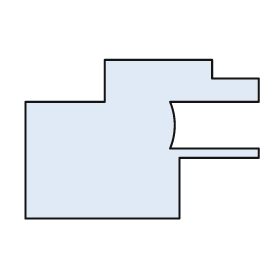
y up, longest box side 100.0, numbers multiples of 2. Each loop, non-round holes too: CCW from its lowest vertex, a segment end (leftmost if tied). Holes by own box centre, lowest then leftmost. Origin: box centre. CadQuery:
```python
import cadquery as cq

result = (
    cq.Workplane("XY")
    .moveTo(-50.0, -34.0)
    .lineTo(16.0, -34.0)
    .lineTo(16.0, -8.0)
    .lineTo(50.0, -8.0)
    .lineTo(50.0, -4.0)
    .lineTo(12.0, -4.0)
    .threePointArc((14.0, 6.0), (12.0, 16.0))
    .lineTo(50.0, 16.0)
    .lineTo(50.0, 26.0)
    .lineTo(30.0, 26.0)
    .lineTo(30.0, 34.0)
    .lineTo(-16.0, 34.0)
    .lineTo(-16.0, 16.0)
    .lineTo(-50.0, 16.0)
    .close()
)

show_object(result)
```